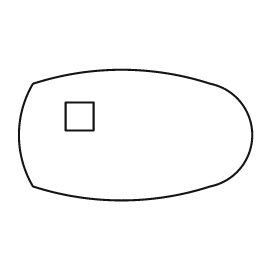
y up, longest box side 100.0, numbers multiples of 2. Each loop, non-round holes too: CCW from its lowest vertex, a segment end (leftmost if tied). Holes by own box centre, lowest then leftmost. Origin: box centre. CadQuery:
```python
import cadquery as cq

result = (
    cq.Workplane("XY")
    .moveTo(-44.0, -22.0)
    .threePointArc((-6.0, -28.0), (32.0, -22.0))
    .threePointArc((50.0, 0.0), (32.0, 22.0))
    .threePointArc((-6.0, 28.0), (-44.0, 22.0))
    .threePointArc((-50.0, 0.0), (-44.0, -22.0))
    .close()
    .moveTo(-30.0, 2.0)
    .lineTo(-18.0, 2.0)
    .lineTo(-18.0, 14.0)
    .lineTo(-30.0, 14.0)
    .close()
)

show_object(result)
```